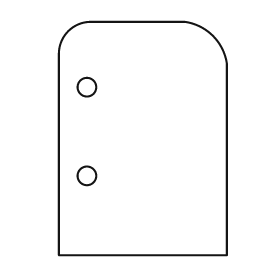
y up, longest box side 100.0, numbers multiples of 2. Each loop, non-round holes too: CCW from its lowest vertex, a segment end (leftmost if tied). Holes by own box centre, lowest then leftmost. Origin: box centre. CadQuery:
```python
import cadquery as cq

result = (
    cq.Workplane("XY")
    .moveTo(-36.0, -50.0)
    .lineTo(36.0, -50.0)
    .lineTo(36.0, 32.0)
    .threePointArc((30.0, 44.0), (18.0, 50.0))
    .lineTo(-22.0, 50.0)
    .threePointArc((-32.0, 46.0), (-36.0, 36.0))
    .close()
    .moveTo(-24.0, -16.0)
    .circle(4.0)
    .moveTo(-24.0, 22.0)
    .circle(4.0)
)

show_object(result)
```